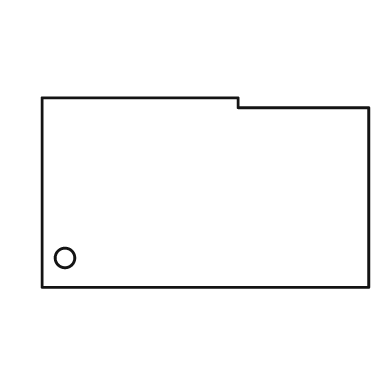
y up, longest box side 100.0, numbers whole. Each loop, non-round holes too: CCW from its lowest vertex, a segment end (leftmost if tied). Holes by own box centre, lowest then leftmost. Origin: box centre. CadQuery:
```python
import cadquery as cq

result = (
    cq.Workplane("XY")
    .moveTo(-50.0, -29.0)
    .lineTo(50.0, -29.0)
    .lineTo(50.0, 26.0)
    .lineTo(10.0, 26.0)
    .lineTo(10.0, 29.0)
    .lineTo(-50.0, 29.0)
    .close()
    .moveTo(-43.0, -20.0)
    .circle(3.0)
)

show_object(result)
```